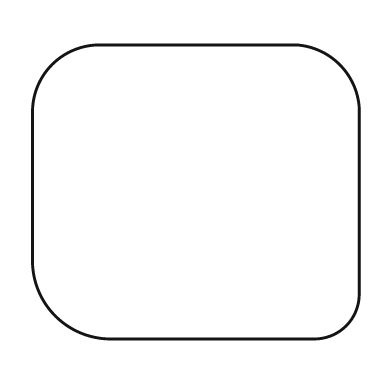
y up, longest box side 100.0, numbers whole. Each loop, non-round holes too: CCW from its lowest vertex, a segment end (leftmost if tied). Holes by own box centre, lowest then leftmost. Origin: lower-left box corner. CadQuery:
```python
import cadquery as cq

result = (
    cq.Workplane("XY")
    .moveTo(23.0, 0.0)
    .lineTo(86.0, 0.0)
    .threePointArc((96.0, 4.0), (100.0, 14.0))
    .lineTo(100.0, 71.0)
    .threePointArc((94.0, 84.0), (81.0, 90.0))
    .lineTo(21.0, 90.0)
    .threePointArc((6.0, 84.0), (0.0, 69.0))
    .lineTo(0.0, 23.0)
    .threePointArc((7.0, 7.0), (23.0, 0.0))
    .close()
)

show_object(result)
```